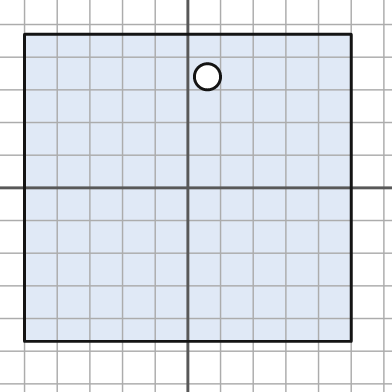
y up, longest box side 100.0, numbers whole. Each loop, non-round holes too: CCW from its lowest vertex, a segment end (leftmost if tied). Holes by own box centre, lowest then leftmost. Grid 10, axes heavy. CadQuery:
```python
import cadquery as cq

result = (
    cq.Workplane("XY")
    .moveTo(-50.0, -47.0)
    .lineTo(50.0, -47.0)
    .lineTo(50.0, 47.0)
    .lineTo(-50.0, 47.0)
    .close()
    .moveTo(6.0, 34.0)
    .circle(4.0)
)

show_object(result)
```